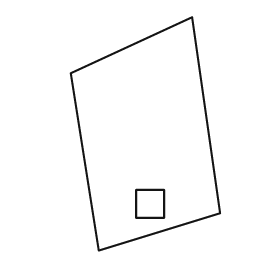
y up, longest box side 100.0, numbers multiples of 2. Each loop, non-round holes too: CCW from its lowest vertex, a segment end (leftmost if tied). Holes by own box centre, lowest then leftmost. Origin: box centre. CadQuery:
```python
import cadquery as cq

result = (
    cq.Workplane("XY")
    .moveTo(-20.0, -50.0)
    .lineTo(32.0, -34.0)
    .lineTo(20.0, 50.0)
    .lineTo(-32.0, 26.0)
    .close()
    .moveTo(-4.0, -36.0)
    .lineTo(8.0, -36.0)
    .lineTo(8.0, -24.0)
    .lineTo(-4.0, -24.0)
    .close()
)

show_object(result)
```